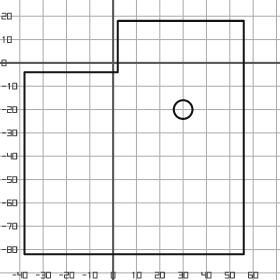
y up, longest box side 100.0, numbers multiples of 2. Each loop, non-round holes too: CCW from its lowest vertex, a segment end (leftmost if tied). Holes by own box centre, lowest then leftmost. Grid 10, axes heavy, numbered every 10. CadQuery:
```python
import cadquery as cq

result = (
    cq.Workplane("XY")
    .moveTo(-38.0, -82.0)
    .lineTo(56.0, -82.0)
    .lineTo(56.0, 18.0)
    .lineTo(2.0, 18.0)
    .lineTo(2.0, -4.0)
    .lineTo(-38.0, -4.0)
    .close()
    .moveTo(30.0, -20.0)
    .circle(4.0)
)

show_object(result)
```